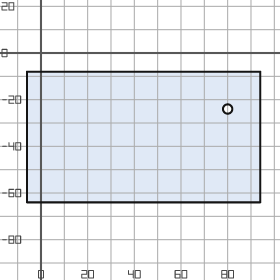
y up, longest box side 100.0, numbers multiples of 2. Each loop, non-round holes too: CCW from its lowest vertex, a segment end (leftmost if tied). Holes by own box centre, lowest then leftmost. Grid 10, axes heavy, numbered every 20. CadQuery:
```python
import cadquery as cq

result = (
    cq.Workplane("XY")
    .moveTo(-6.0, -64.0)
    .lineTo(94.0, -64.0)
    .lineTo(94.0, -8.0)
    .lineTo(-6.0, -8.0)
    .close()
    .moveTo(80.0, -24.0)
    .circle(2.0)
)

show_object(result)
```